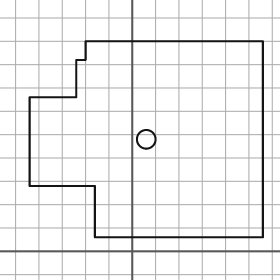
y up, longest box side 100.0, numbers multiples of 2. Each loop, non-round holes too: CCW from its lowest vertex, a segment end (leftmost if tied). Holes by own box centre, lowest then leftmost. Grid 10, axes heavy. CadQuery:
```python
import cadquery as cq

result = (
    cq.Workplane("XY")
    .moveTo(-16.0, 6.0)
    .lineTo(56.0, 6.0)
    .lineTo(56.0, 90.0)
    .lineTo(-20.0, 90.0)
    .lineTo(-20.0, 82.0)
    .lineTo(-24.0, 82.0)
    .lineTo(-24.0, 66.0)
    .lineTo(-44.0, 66.0)
    .lineTo(-44.0, 28.0)
    .lineTo(-16.0, 28.0)
    .close()
    .moveTo(6.0, 48.0)
    .circle(4.0)
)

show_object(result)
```